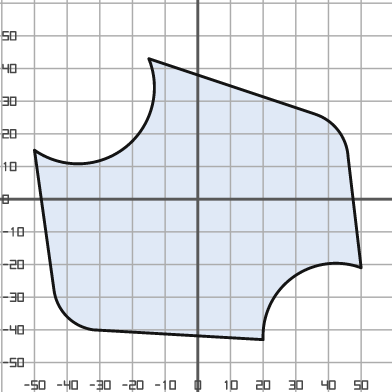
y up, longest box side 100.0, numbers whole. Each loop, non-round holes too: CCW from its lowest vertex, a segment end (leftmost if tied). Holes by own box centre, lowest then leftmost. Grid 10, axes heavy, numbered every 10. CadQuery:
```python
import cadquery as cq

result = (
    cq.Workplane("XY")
    .moveTo(20.0, -43.0)
    .threePointArc((29.0, -24.0), (50.0, -21.0))
    .lineTo(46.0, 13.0)
    .threePointArc((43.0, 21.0), (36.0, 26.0))
    .lineTo(-15.0, 43.0)
    .threePointArc((-22.0, 16.0), (-50.0, 15.0))
    .lineTo(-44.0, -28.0)
    .threePointArc((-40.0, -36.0), (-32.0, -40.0))
    .close()
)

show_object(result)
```